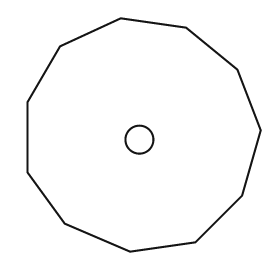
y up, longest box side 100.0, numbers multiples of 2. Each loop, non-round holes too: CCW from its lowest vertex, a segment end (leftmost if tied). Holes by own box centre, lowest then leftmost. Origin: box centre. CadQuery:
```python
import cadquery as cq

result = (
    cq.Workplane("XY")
    .moveTo(-6.0, -50.0)
    .lineTo(22.0, -46.0)
    .lineTo(42.0, -26.0)
    .lineTo(50.0, 2.0)
    .lineTo(40.0, 28.0)
    .lineTo(18.0, 46.0)
    .lineTo(-10.0, 50.0)
    .lineTo(-36.0, 38.0)
    .lineTo(-50.0, 14.0)
    .lineTo(-50.0, -16.0)
    .lineTo(-34.0, -38.0)
    .close()
    .moveTo(-2.0, -2.0)
    .circle(6.0)
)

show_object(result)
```